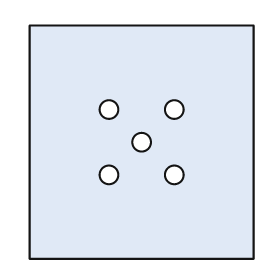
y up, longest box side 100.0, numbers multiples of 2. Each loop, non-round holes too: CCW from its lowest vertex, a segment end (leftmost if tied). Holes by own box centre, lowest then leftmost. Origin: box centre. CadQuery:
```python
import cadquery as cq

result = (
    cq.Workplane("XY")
    .moveTo(-48.0, -50.0)
    .lineTo(48.0, -50.0)
    .lineTo(48.0, 50.0)
    .lineTo(-48.0, 50.0)
    .close()
    .moveTo(-14.0, -14.0)
    .circle(4.0)
    .moveTo(14.0, -14.0)
    .circle(4.0)
    .moveTo(0.0, 0.0)
    .circle(4.0)
    .moveTo(-14.0, 14.0)
    .circle(4.0)
    .moveTo(14.0, 14.0)
    .circle(4.0)
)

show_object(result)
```